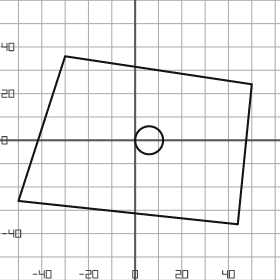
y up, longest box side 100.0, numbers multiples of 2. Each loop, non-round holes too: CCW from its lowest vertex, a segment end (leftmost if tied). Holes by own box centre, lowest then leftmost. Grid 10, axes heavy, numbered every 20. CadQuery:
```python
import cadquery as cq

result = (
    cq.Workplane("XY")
    .moveTo(44.0, -36.0)
    .lineTo(50.0, 24.0)
    .lineTo(-30.0, 36.0)
    .lineTo(-50.0, -26.0)
    .close()
    .moveTo(6.0, 0.0)
    .circle(6.0)
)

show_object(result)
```